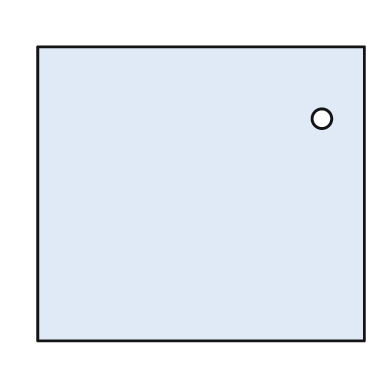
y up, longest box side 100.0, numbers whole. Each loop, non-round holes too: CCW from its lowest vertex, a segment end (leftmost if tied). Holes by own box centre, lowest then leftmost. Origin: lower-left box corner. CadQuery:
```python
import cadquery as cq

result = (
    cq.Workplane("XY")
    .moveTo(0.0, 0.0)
    .lineTo(100.0, 0.0)
    .lineTo(100.0, 90.0)
    .lineTo(0.0, 90.0)
    .close()
    .moveTo(87.0, 68.0)
    .circle(3.0)
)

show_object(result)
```